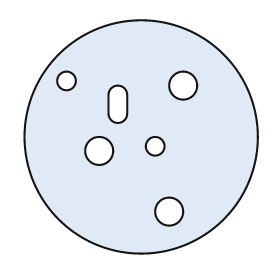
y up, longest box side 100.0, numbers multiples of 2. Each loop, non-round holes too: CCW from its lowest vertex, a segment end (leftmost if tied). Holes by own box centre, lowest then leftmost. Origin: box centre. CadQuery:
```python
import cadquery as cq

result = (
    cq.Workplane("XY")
    .moveTo(0.0, 0.0)
    .circle(50.0)
    .moveTo(12.0, -32.0)
    .circle(6.0)
    .moveTo(-18.0, -6.0)
    .circle(6.0)
    .moveTo(6.0, -4.0)
    .circle(4.0)
    .moveTo(-14.0, 10.0)
    .threePointArc((-10.0, 6.0), (-6.0, 10.0))
    .lineTo(-6.0, 18.0)
    .threePointArc((-10.0, 22.0), (-14.0, 18.0))
    .close()
    .moveTo(18.0, 22.0)
    .circle(6.0)
    .moveTo(-32.0, 24.0)
    .circle(4.0)
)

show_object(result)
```